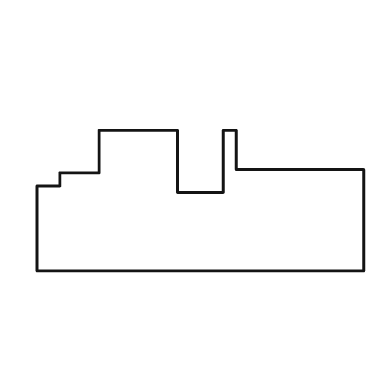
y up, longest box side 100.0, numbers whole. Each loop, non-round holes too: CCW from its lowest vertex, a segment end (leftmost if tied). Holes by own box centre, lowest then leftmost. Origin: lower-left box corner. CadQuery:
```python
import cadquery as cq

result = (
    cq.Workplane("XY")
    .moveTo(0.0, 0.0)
    .lineTo(100.0, 0.0)
    .lineTo(100.0, 31.0)
    .lineTo(61.0, 31.0)
    .lineTo(61.0, 43.0)
    .lineTo(57.0, 43.0)
    .lineTo(57.0, 24.0)
    .lineTo(43.0, 24.0)
    .lineTo(43.0, 43.0)
    .lineTo(19.0, 43.0)
    .lineTo(19.0, 30.0)
    .lineTo(7.0, 30.0)
    .lineTo(7.0, 26.0)
    .lineTo(0.0, 26.0)
    .close()
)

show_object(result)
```